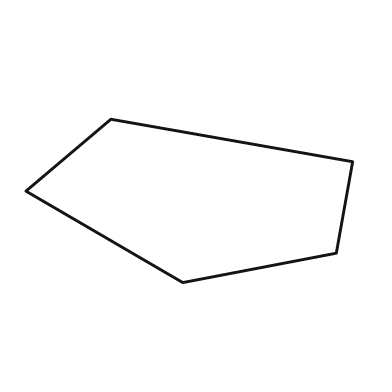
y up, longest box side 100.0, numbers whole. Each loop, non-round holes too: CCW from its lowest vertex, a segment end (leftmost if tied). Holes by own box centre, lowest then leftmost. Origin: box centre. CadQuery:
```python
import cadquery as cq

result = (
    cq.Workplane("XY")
    .moveTo(-2.0, -25.0)
    .lineTo(45.0, -16.0)
    .lineTo(50.0, 12.0)
    .lineTo(-24.0, 25.0)
    .lineTo(-50.0, 3.0)
    .close()
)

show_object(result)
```